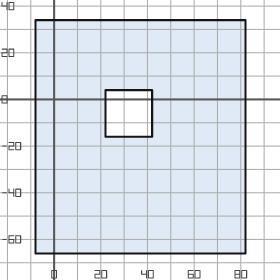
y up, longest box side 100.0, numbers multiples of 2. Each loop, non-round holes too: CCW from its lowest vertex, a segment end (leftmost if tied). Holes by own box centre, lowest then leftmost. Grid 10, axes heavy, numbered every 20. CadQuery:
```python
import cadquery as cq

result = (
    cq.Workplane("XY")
    .moveTo(-8.0, -66.0)
    .lineTo(82.0, -66.0)
    .lineTo(82.0, 34.0)
    .lineTo(-8.0, 34.0)
    .close()
    .moveTo(22.0, -16.0)
    .lineTo(42.0, -16.0)
    .lineTo(42.0, 4.0)
    .lineTo(22.0, 4.0)
    .close()
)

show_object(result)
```